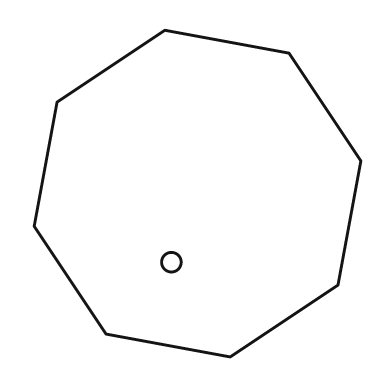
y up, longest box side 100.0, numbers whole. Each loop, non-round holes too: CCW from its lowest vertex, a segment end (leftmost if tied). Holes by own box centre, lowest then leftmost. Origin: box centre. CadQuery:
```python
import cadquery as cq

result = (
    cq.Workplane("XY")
    .moveTo(10.0, -50.0)
    .lineTo(43.0, -28.0)
    .lineTo(50.0, 10.0)
    .lineTo(28.0, 43.0)
    .lineTo(-10.0, 50.0)
    .lineTo(-43.0, 28.0)
    .lineTo(-50.0, -10.0)
    .lineTo(-28.0, -43.0)
    .close()
    .moveTo(-8.0, -21.0)
    .circle(3.0)
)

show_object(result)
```